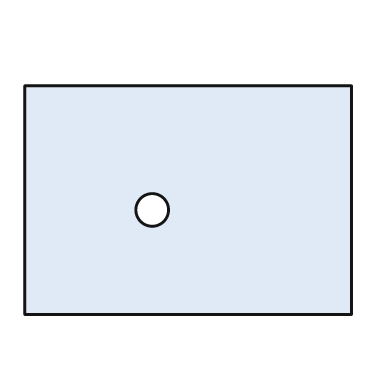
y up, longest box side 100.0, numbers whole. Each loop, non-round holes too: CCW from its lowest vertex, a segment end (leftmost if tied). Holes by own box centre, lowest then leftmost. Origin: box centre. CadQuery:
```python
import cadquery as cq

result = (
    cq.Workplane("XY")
    .moveTo(-50.0, -35.0)
    .lineTo(50.0, -35.0)
    .lineTo(50.0, 35.0)
    .lineTo(-50.0, 35.0)
    .close()
    .moveTo(-11.0, -3.0)
    .circle(5.0)
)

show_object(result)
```